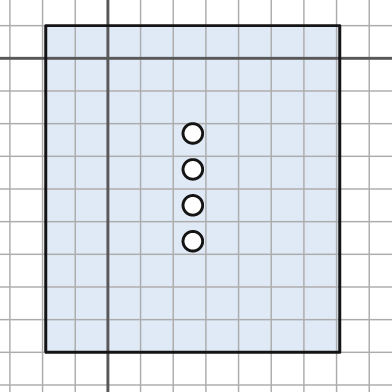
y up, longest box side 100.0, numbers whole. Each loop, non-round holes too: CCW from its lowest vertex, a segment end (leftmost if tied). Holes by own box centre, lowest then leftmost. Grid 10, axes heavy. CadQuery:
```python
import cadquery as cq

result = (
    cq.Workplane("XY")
    .moveTo(-19.0, -90.0)
    .lineTo(71.0, -90.0)
    .lineTo(71.0, 10.0)
    .lineTo(-19.0, 10.0)
    .close()
    .moveTo(26.0, -56.0)
    .circle(3.0)
    .moveTo(26.0, -45.0)
    .circle(3.0)
    .moveTo(26.0, -34.0)
    .circle(3.0)
    .moveTo(26.0, -23.0)
    .circle(3.0)
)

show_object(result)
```